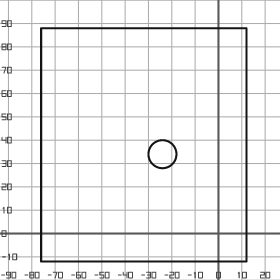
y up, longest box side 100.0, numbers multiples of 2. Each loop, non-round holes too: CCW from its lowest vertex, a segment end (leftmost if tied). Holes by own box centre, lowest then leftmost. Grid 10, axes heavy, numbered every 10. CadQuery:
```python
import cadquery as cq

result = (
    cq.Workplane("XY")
    .moveTo(-76.0, -12.0)
    .lineTo(12.0, -12.0)
    .lineTo(12.0, 88.0)
    .lineTo(-76.0, 88.0)
    .close()
    .moveTo(-24.0, 34.0)
    .circle(6.0)
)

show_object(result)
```